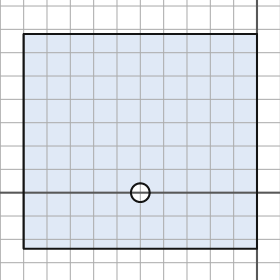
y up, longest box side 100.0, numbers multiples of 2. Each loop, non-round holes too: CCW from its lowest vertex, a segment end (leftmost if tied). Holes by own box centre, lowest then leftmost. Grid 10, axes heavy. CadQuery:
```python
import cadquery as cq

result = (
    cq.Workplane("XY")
    .moveTo(-100.0, -24.0)
    .lineTo(0.0, -24.0)
    .lineTo(0.0, 68.0)
    .lineTo(-100.0, 68.0)
    .close()
    .moveTo(-50.0, 0.0)
    .circle(4.0)
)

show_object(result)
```